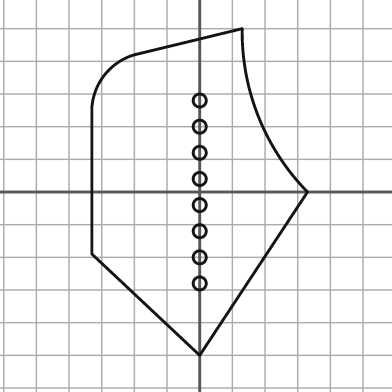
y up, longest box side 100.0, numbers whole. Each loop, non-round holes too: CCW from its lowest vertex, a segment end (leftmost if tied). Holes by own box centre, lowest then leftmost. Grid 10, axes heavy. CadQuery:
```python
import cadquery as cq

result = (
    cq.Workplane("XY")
    .moveTo(0.0, -50.0)
    .lineTo(33.0, 0.0)
    .threePointArc((18.0, 23.0), (13.0, 50.0))
    .lineTo(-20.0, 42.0)
    .threePointArc((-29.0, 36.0), (-33.0, 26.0))
    .lineTo(-33.0, -19.0)
    .close()
    .moveTo(0.0, -28.0)
    .circle(2.0)
    .moveTo(0.0, -20.0)
    .circle(2.0)
    .moveTo(0.0, -12.0)
    .circle(2.0)
    .moveTo(0.0, -4.0)
    .circle(2.0)
    .moveTo(0.0, 4.0)
    .circle(2.0)
    .moveTo(0.0, 12.0)
    .circle(2.0)
    .moveTo(0.0, 20.0)
    .circle(2.0)
    .moveTo(0.0, 28.0)
    .circle(2.0)
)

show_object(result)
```